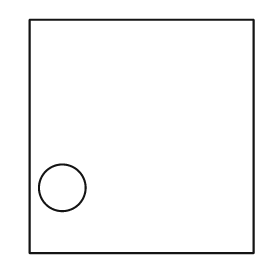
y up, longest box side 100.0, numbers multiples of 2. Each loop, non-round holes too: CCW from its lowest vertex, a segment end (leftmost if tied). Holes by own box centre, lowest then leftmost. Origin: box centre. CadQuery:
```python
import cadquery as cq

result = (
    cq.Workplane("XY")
    .moveTo(-48.0, -50.0)
    .lineTo(48.0, -50.0)
    .lineTo(48.0, 50.0)
    .lineTo(-48.0, 50.0)
    .close()
    .moveTo(-34.0, -22.0)
    .circle(10.0)
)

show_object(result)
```